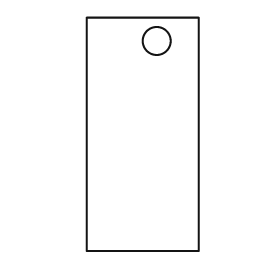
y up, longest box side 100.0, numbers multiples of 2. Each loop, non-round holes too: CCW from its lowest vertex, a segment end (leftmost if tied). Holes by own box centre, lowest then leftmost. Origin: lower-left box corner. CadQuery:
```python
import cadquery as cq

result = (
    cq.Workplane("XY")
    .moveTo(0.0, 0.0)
    .lineTo(48.0, 0.0)
    .lineTo(48.0, 100.0)
    .lineTo(0.0, 100.0)
    .close()
    .moveTo(30.0, 90.0)
    .circle(6.0)
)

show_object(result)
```